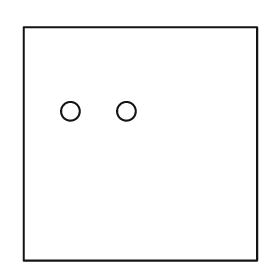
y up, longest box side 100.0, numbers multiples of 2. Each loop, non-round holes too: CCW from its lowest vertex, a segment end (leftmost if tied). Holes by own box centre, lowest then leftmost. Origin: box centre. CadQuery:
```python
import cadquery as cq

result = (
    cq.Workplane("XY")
    .moveTo(-50.0, -50.0)
    .lineTo(50.0, -50.0)
    .lineTo(50.0, 50.0)
    .lineTo(-50.0, 50.0)
    .close()
    .moveTo(-30.0, 14.0)
    .circle(4.0)
    .moveTo(-6.0, 14.0)
    .circle(4.0)
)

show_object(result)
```